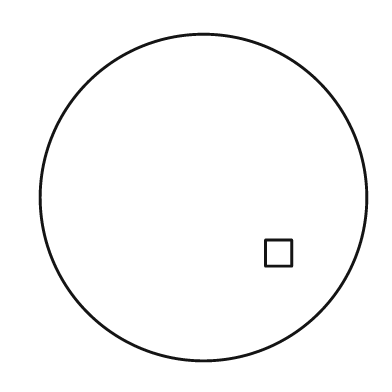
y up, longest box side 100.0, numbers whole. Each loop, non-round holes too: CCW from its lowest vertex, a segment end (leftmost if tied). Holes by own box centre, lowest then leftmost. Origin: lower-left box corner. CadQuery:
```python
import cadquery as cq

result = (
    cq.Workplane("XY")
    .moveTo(50.0, 50.0)
    .circle(50.0)
    .moveTo(69.0, 29.0)
    .lineTo(77.0, 29.0)
    .lineTo(77.0, 37.0)
    .lineTo(69.0, 37.0)
    .close()
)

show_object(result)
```